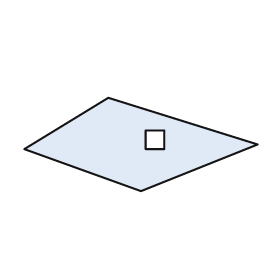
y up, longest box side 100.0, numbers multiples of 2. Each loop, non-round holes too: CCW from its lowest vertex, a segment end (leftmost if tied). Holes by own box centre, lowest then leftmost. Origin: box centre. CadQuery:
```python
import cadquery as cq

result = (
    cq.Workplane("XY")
    .moveTo(0.0, -20.0)
    .lineTo(50.0, 0.0)
    .lineTo(-14.0, 20.0)
    .lineTo(-50.0, -2.0)
    .close()
    .moveTo(2.0, -2.0)
    .lineTo(10.0, -2.0)
    .lineTo(10.0, 6.0)
    .lineTo(2.0, 6.0)
    .close()
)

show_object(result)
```